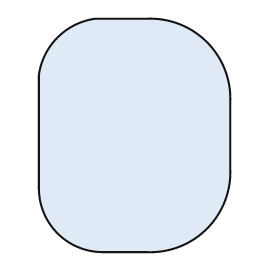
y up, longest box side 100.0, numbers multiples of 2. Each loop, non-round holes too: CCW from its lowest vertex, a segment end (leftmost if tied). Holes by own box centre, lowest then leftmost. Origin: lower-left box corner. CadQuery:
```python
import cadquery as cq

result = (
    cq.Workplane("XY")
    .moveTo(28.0, 0.0)
    .lineTo(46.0, 0.0)
    .threePointArc((72.0, 10.0), (82.0, 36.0))
    .lineTo(82.0, 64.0)
    .threePointArc((72.0, 90.0), (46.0, 100.0))
    .lineTo(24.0, 100.0)
    .threePointArc((8.0, 92.0), (0.0, 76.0))
    .lineTo(0.0, 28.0)
    .threePointArc((8.0, 8.0), (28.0, 0.0))
    .close()
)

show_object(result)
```